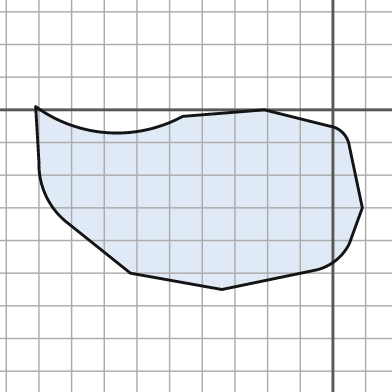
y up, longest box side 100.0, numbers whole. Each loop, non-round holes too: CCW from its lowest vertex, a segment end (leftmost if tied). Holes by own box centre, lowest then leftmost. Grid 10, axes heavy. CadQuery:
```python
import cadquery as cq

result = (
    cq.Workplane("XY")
    .moveTo(-34.0, -55.0)
    .lineTo(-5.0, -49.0)
    .threePointArc((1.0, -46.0), (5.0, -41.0))
    .lineTo(9.0, -30.0)
    .lineTo(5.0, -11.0)
    .threePointArc((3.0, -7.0), (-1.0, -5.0))
    .lineTo(-21.0, 0.0)
    .lineTo(-46.0, -2.0)
    .threePointArc((-69.0, -7.0), (-91.0, 1.0))
    .lineTo(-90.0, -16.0)
    .threePointArc((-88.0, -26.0), (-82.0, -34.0))
    .lineTo(-62.0, -50.0)
    .close()
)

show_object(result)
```